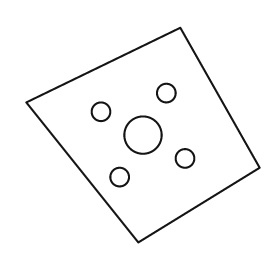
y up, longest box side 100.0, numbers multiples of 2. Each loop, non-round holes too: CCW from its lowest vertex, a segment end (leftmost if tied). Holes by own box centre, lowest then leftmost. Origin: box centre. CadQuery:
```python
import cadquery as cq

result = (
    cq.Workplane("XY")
    .moveTo(-2.0, -46.0)
    .lineTo(50.0, -14.0)
    .lineTo(16.0, 46.0)
    .lineTo(-50.0, 14.0)
    .close()
    .moveTo(-10.0, -18.0)
    .circle(4.0)
    .moveTo(18.0, -10.0)
    .circle(4.0)
    .moveTo(0.0, 0.0)
    .circle(8.0)
    .moveTo(-18.0, 10.0)
    .circle(4.0)
    .moveTo(10.0, 18.0)
    .circle(4.0)
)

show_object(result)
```